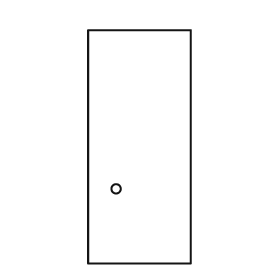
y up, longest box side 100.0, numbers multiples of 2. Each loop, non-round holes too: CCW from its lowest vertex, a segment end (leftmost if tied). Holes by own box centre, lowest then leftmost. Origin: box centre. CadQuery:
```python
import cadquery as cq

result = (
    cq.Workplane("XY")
    .moveTo(-22.0, -50.0)
    .lineTo(22.0, -50.0)
    .lineTo(22.0, 50.0)
    .lineTo(-22.0, 50.0)
    .close()
    .moveTo(-10.0, -18.0)
    .circle(2.0)
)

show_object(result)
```